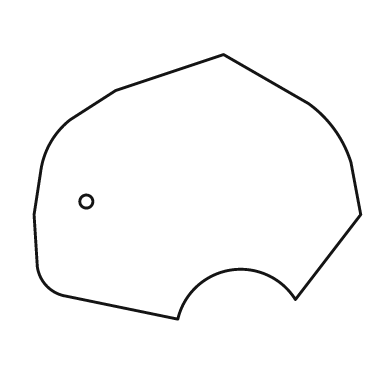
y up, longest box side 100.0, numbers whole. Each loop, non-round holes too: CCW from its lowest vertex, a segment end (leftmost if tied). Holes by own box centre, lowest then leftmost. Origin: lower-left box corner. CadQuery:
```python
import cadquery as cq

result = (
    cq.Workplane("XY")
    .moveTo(44.0, 0.0)
    .threePointArc((60.0, 15.0), (80.0, 6.0))
    .lineTo(100.0, 32.0)
    .lineTo(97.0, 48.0)
    .threePointArc((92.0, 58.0), (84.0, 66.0))
    .lineTo(58.0, 81.0)
    .lineTo(25.0, 70.0)
    .lineTo(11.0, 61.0)
    .threePointArc((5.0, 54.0), (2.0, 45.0))
    .lineTo(0.0, 32.0)
    .lineTo(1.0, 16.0)
    .threePointArc((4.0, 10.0), (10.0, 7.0))
    .close()
    .moveTo(16.0, 36.0)
    .circle(2.0)
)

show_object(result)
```